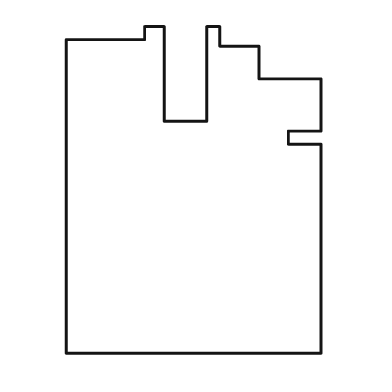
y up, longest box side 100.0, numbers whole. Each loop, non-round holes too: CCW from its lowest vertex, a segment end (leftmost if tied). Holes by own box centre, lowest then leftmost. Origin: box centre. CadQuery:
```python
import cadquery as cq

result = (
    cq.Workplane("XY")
    .moveTo(-39.0, -50.0)
    .lineTo(39.0, -50.0)
    .lineTo(39.0, 14.0)
    .lineTo(29.0, 14.0)
    .lineTo(29.0, 18.0)
    .lineTo(39.0, 18.0)
    .lineTo(39.0, 34.0)
    .lineTo(20.0, 34.0)
    .lineTo(20.0, 44.0)
    .lineTo(8.0, 44.0)
    .lineTo(8.0, 50.0)
    .lineTo(4.0, 50.0)
    .lineTo(4.0, 21.0)
    .lineTo(-9.0, 21.0)
    .lineTo(-9.0, 50.0)
    .lineTo(-15.0, 50.0)
    .lineTo(-15.0, 46.0)
    .lineTo(-39.0, 46.0)
    .close()
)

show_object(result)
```